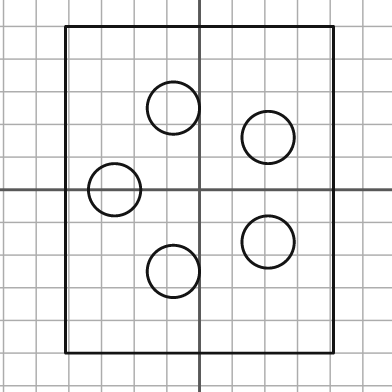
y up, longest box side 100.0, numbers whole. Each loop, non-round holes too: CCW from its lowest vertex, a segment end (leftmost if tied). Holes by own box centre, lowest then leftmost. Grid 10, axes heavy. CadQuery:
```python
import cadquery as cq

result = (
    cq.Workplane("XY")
    .moveTo(-41.0, -50.0)
    .lineTo(41.0, -50.0)
    .lineTo(41.0, 50.0)
    .lineTo(-41.0, 50.0)
    .close()
    .moveTo(-8.0, -25.0)
    .circle(8.0)
    .moveTo(21.0, -16.0)
    .circle(8.0)
    .moveTo(-26.0, 0.0)
    .circle(8.0)
    .moveTo(21.0, 16.0)
    .circle(8.0)
    .moveTo(-8.0, 25.0)
    .circle(8.0)
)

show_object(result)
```